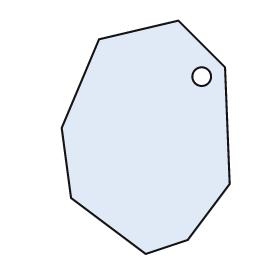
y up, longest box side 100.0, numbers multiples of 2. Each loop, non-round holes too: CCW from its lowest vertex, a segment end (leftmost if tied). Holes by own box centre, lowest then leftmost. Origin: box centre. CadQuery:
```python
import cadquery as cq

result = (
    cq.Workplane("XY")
    .moveTo(0.0, -50.0)
    .lineTo(18.0, -44.0)
    .lineTo(36.0, -20.0)
    .lineTo(34.0, 30.0)
    .lineTo(14.0, 50.0)
    .lineTo(-20.0, 42.0)
    .lineTo(-36.0, 4.0)
    .lineTo(-32.0, -26.0)
    .close()
    .moveTo(24.0, 26.0)
    .circle(4.0)
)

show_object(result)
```